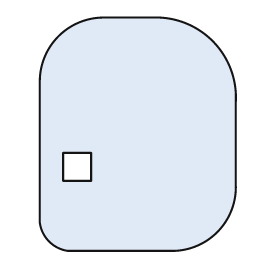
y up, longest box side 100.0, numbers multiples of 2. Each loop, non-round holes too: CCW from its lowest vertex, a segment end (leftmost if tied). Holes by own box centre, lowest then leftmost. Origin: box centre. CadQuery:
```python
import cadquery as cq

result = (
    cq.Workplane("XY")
    .moveTo(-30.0, -50.0)
    .lineTo(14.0, -50.0)
    .threePointArc((34.0, -42.0), (42.0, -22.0))
    .lineTo(42.0, 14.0)
    .threePointArc((32.0, 40.0), (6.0, 50.0))
    .lineTo(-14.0, 50.0)
    .threePointArc((-34.0, 42.0), (-42.0, 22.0))
    .lineTo(-42.0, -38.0)
    .threePointArc((-38.0, -46.0), (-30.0, -50.0))
    .close()
    .moveTo(-32.0, -20.0)
    .lineTo(-20.0, -20.0)
    .lineTo(-20.0, -8.0)
    .lineTo(-32.0, -8.0)
    .close()
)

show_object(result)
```